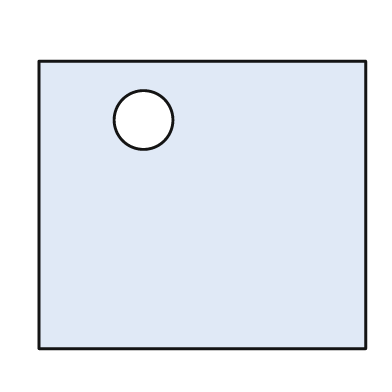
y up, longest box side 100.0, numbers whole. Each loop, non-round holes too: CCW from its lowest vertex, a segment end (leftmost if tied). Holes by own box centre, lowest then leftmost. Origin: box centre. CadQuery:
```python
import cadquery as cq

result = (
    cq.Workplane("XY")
    .moveTo(-50.0, -44.0)
    .lineTo(50.0, -44.0)
    .lineTo(50.0, 44.0)
    .lineTo(-50.0, 44.0)
    .close()
    .moveTo(-18.0, 26.0)
    .circle(9.0)
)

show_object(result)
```